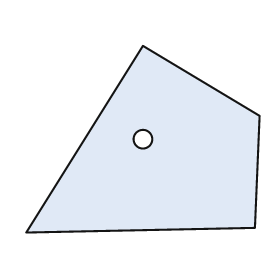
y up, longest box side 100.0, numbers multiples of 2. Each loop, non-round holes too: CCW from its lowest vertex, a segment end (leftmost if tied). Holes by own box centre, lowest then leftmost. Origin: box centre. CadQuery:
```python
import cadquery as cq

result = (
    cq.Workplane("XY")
    .moveTo(-50.0, -40.0)
    .lineTo(48.0, -38.0)
    .lineTo(50.0, 10.0)
    .lineTo(0.0, 40.0)
    .close()
    .moveTo(0.0, 0.0)
    .circle(4.0)
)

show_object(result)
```